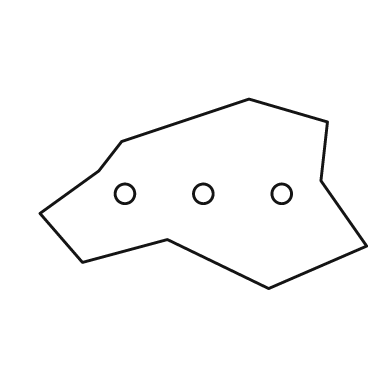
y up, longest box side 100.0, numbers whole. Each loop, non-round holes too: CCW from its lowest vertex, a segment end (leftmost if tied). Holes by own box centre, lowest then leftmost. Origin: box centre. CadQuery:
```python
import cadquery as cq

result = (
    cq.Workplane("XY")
    .moveTo(20.0, -29.0)
    .lineTo(50.0, -16.0)
    .lineTo(36.0, 4.0)
    .lineTo(38.0, 22.0)
    .lineTo(14.0, 29.0)
    .lineTo(-25.0, 16.0)
    .lineTo(-32.0, 7.0)
    .lineTo(-50.0, -6.0)
    .lineTo(-37.0, -21.0)
    .lineTo(-11.0, -14.0)
    .close()
    .moveTo(-24.0, 0.0)
    .circle(3.0)
    .moveTo(0.0, 0.0)
    .circle(3.0)
    .moveTo(24.0, 0.0)
    .circle(3.0)
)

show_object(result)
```